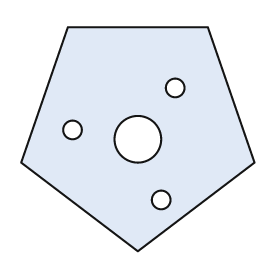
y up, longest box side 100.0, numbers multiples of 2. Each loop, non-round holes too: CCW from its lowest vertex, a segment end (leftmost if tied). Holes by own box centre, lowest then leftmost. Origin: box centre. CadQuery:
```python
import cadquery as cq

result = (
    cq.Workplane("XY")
    .moveTo(0.0, -48.0)
    .lineTo(50.0, -10.0)
    .lineTo(30.0, 48.0)
    .lineTo(-30.0, 48.0)
    .lineTo(-50.0, -10.0)
    .close()
    .moveTo(10.0, -26.0)
    .circle(4.0)
    .moveTo(0.0, 0.0)
    .circle(10.0)
    .moveTo(-28.0, 4.0)
    .circle(4.0)
    .moveTo(16.0, 22.0)
    .circle(4.0)
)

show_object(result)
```